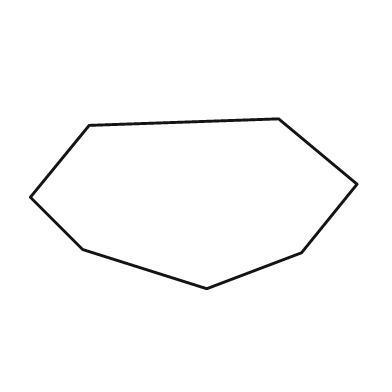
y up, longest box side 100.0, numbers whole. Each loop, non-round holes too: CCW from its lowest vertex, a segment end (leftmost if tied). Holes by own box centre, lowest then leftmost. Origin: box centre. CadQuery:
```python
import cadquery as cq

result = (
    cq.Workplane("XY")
    .moveTo(4.0, -26.0)
    .lineTo(33.0, -15.0)
    .lineTo(50.0, 6.0)
    .lineTo(26.0, 26.0)
    .lineTo(-32.0, 24.0)
    .lineTo(-50.0, 2.0)
    .lineTo(-34.0, -14.0)
    .close()
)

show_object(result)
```